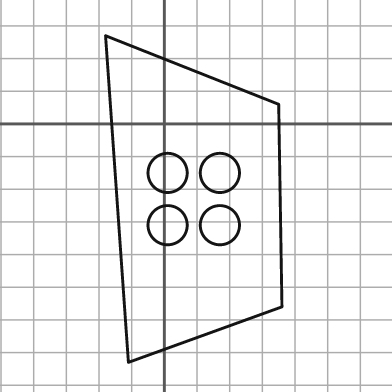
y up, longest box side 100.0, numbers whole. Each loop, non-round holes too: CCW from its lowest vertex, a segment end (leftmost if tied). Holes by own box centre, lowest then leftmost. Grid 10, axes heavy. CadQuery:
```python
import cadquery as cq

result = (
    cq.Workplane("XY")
    .moveTo(-11.0, -73.0)
    .lineTo(36.0, -56.0)
    .lineTo(35.0, 6.0)
    .lineTo(-18.0, 27.0)
    .close()
    .moveTo(1.0, -31.0)
    .circle(6.0)
    .moveTo(17.0, -31.0)
    .circle(6.0)
    .moveTo(1.0, -15.0)
    .circle(6.0)
    .moveTo(17.0, -15.0)
    .circle(6.0)
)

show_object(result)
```